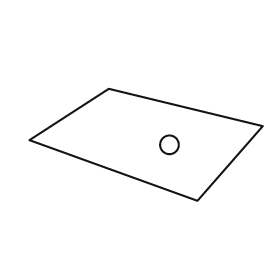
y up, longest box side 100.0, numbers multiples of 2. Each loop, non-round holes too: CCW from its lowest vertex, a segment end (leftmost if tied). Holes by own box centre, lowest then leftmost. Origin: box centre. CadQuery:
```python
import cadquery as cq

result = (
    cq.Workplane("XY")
    .moveTo(22.0, -24.0)
    .lineTo(50.0, 8.0)
    .lineTo(-16.0, 24.0)
    .lineTo(-50.0, 2.0)
    .close()
    .moveTo(10.0, 0.0)
    .circle(4.0)
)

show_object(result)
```